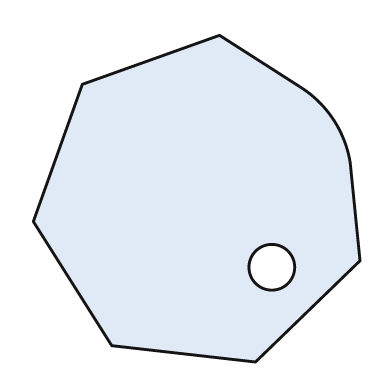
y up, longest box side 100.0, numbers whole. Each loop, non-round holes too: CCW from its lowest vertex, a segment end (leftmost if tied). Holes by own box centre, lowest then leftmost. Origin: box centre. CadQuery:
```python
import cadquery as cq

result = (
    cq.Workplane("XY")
    .moveTo(18.0, -50.0)
    .lineTo(50.0, -19.0)
    .lineTo(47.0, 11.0)
    .threePointArc((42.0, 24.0), (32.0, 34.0))
    .lineTo(7.0, 50.0)
    .lineTo(-35.0, 35.0)
    .lineTo(-50.0, -7.0)
    .lineTo(-26.0, -45.0)
    .close()
    .moveTo(23.0, -21.0)
    .circle(7.0)
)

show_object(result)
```